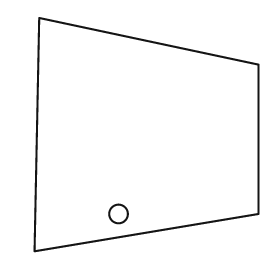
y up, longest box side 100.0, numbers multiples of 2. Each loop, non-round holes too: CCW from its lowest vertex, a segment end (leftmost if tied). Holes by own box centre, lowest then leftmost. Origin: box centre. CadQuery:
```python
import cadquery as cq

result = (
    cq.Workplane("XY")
    .moveTo(-48.0, -50.0)
    .lineTo(48.0, -34.0)
    .lineTo(48.0, 30.0)
    .lineTo(-46.0, 50.0)
    .close()
    .moveTo(-12.0, -34.0)
    .circle(4.0)
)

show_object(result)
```